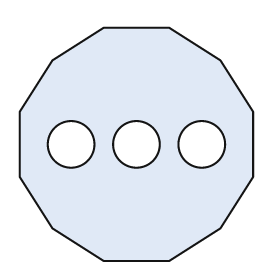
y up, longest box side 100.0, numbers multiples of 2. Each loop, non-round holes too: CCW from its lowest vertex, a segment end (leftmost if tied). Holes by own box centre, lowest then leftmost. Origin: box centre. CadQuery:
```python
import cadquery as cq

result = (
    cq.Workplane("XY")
    .moveTo(-14.0, -50.0)
    .lineTo(14.0, -50.0)
    .lineTo(36.0, -36.0)
    .lineTo(50.0, -14.0)
    .lineTo(50.0, 14.0)
    .lineTo(36.0, 36.0)
    .lineTo(14.0, 50.0)
    .lineTo(-14.0, 50.0)
    .lineTo(-36.0, 36.0)
    .lineTo(-50.0, 14.0)
    .lineTo(-50.0, -14.0)
    .lineTo(-36.0, -36.0)
    .close()
    .moveTo(-28.0, 0.0)
    .circle(10.0)
    .moveTo(0.0, 0.0)
    .circle(10.0)
    .moveTo(28.0, 0.0)
    .circle(10.0)
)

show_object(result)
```